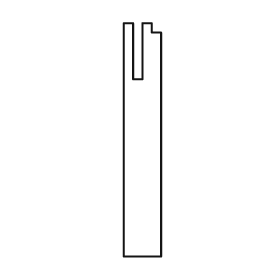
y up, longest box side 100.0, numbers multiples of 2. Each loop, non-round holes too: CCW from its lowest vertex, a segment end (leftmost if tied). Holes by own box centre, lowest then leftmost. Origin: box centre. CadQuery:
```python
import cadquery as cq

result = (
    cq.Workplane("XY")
    .moveTo(-8.0, -50.0)
    .lineTo(8.0, -50.0)
    .lineTo(8.0, 46.0)
    .lineTo(4.0, 46.0)
    .lineTo(4.0, 50.0)
    .lineTo(0.0, 50.0)
    .lineTo(0.0, 26.0)
    .lineTo(-4.0, 26.0)
    .lineTo(-4.0, 50.0)
    .lineTo(-8.0, 50.0)
    .close()
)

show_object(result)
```